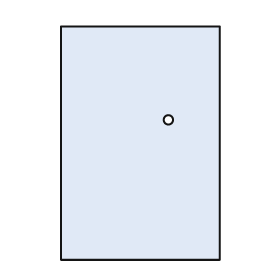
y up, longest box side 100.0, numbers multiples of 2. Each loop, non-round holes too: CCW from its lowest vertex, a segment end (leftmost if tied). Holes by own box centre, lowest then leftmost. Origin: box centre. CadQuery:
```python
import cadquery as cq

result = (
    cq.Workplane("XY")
    .moveTo(-34.0, -50.0)
    .lineTo(34.0, -50.0)
    .lineTo(34.0, 50.0)
    .lineTo(-34.0, 50.0)
    .close()
    .moveTo(12.0, 10.0)
    .circle(2.0)
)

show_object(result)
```